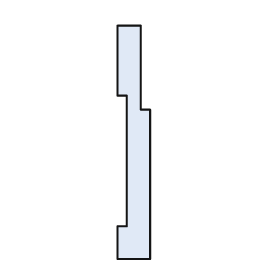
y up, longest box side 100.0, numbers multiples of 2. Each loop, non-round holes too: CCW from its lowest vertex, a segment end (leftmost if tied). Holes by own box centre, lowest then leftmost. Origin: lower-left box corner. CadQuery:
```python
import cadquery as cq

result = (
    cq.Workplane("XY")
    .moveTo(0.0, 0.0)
    .lineTo(14.0, 0.0)
    .lineTo(14.0, 64.0)
    .lineTo(10.0, 64.0)
    .lineTo(10.0, 100.0)
    .lineTo(0.0, 100.0)
    .lineTo(0.0, 70.0)
    .lineTo(4.0, 70.0)
    .lineTo(4.0, 14.0)
    .lineTo(0.0, 14.0)
    .close()
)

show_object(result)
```